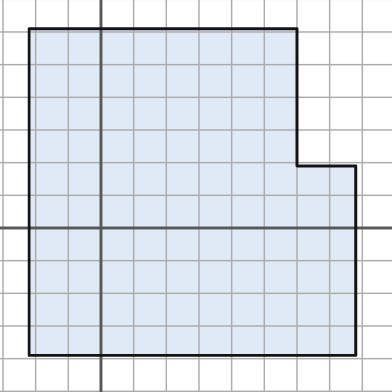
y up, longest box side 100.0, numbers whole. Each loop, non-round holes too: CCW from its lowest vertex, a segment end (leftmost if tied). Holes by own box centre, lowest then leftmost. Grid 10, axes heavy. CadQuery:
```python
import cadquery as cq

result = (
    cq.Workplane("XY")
    .moveTo(-22.0, -39.0)
    .lineTo(78.0, -39.0)
    .lineTo(78.0, 19.0)
    .lineTo(60.0, 19.0)
    .lineTo(60.0, 61.0)
    .lineTo(-22.0, 61.0)
    .close()
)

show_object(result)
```